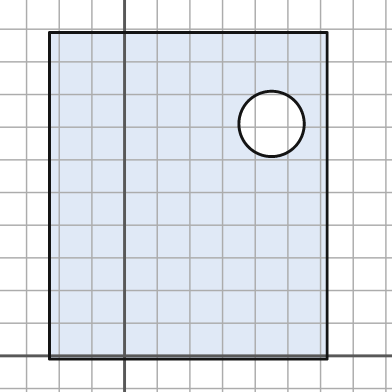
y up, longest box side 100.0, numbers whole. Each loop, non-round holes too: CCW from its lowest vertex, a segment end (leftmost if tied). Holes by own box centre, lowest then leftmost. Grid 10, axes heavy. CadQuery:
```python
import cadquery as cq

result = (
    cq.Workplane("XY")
    .moveTo(-23.0, -1.0)
    .lineTo(62.0, -1.0)
    .lineTo(62.0, 99.0)
    .lineTo(-23.0, 99.0)
    .close()
    .moveTo(45.0, 71.0)
    .circle(10.0)
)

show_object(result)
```